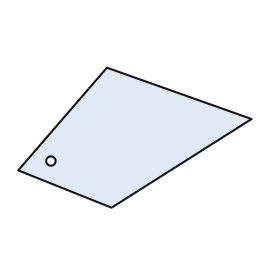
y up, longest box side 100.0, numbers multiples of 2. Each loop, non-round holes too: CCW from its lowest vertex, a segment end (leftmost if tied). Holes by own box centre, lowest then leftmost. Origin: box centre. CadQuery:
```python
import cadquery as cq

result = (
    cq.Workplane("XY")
    .moveTo(-10.0, -30.0)
    .lineTo(50.0, 8.0)
    .lineTo(-12.0, 30.0)
    .lineTo(-50.0, -14.0)
    .close()
    .moveTo(-36.0, -10.0)
    .circle(2.0)
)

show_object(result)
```